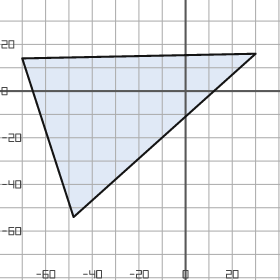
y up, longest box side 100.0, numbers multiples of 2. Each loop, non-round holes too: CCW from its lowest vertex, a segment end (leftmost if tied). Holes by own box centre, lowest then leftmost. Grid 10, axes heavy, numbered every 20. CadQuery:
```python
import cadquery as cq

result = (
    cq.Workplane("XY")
    .moveTo(-48.0, -54.0)
    .lineTo(30.0, 16.0)
    .lineTo(-70.0, 14.0)
    .close()
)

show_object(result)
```